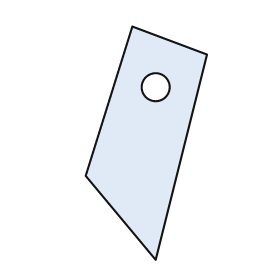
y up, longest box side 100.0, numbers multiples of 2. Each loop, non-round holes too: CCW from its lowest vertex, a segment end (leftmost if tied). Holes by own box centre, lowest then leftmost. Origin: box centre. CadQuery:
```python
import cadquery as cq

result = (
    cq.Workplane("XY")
    .moveTo(4.0, -50.0)
    .lineTo(26.0, 38.0)
    .lineTo(-6.0, 50.0)
    .lineTo(-26.0, -14.0)
    .close()
    .moveTo(4.0, 24.0)
    .circle(6.0)
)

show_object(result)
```